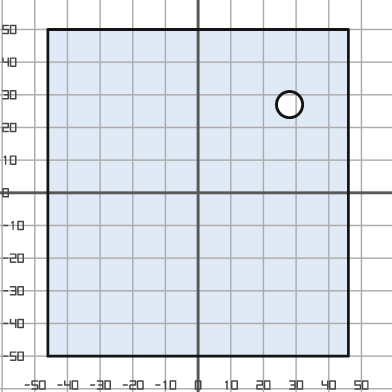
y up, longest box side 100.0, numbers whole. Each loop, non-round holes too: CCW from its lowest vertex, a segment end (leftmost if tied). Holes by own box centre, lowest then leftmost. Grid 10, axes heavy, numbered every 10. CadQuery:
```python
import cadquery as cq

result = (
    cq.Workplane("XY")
    .moveTo(-46.0, -50.0)
    .lineTo(46.0, -50.0)
    .lineTo(46.0, 50.0)
    .lineTo(-46.0, 50.0)
    .close()
    .moveTo(28.0, 27.0)
    .circle(4.0)
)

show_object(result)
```